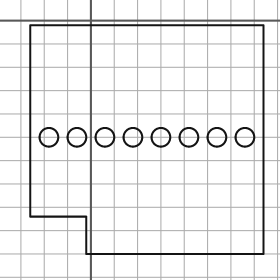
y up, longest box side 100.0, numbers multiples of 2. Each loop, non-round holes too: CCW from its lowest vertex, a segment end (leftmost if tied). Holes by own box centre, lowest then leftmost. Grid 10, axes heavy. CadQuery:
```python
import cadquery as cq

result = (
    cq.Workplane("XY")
    .moveTo(-2.0, -100.0)
    .lineTo(74.0, -100.0)
    .lineTo(74.0, -2.0)
    .lineTo(-26.0, -2.0)
    .lineTo(-26.0, -84.0)
    .lineTo(-2.0, -84.0)
    .close()
    .moveTo(-18.0, -50.0)
    .circle(4.0)
    .moveTo(-6.0, -50.0)
    .circle(4.0)
    .moveTo(6.0, -50.0)
    .circle(4.0)
    .moveTo(18.0, -50.0)
    .circle(4.0)
    .moveTo(30.0, -50.0)
    .circle(4.0)
    .moveTo(42.0, -50.0)
    .circle(4.0)
    .moveTo(54.0, -50.0)
    .circle(4.0)
    .moveTo(66.0, -50.0)
    .circle(4.0)
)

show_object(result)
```